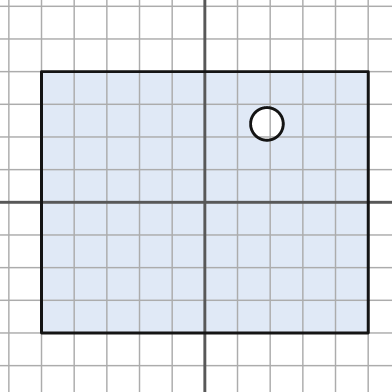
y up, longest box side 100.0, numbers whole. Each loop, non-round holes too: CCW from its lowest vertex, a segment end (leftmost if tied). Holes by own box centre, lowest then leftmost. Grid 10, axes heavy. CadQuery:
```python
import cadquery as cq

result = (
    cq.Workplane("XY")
    .moveTo(-50.0, -40.0)
    .lineTo(50.0, -40.0)
    .lineTo(50.0, 40.0)
    .lineTo(-50.0, 40.0)
    .close()
    .moveTo(19.0, 24.0)
    .circle(5.0)
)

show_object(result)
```